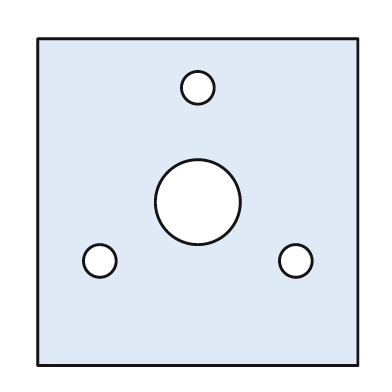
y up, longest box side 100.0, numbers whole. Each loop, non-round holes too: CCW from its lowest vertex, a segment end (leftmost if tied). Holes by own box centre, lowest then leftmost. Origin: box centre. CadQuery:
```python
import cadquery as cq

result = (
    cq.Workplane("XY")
    .moveTo(-49.0, -50.0)
    .lineTo(49.0, -50.0)
    .lineTo(49.0, 50.0)
    .lineTo(-49.0, 50.0)
    .close()
    .moveTo(-30.0, -18.0)
    .circle(5.0)
    .moveTo(30.0, -18.0)
    .circle(5.0)
    .moveTo(0.0, 0.0)
    .circle(13.0)
    .moveTo(0.0, 35.0)
    .circle(5.0)
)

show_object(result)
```